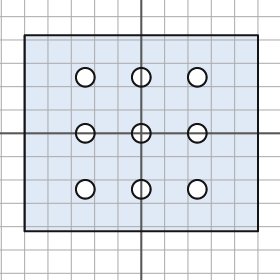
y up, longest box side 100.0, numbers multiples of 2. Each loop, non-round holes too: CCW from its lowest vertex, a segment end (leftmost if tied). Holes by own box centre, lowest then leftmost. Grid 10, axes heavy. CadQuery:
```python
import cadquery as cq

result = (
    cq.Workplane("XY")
    .moveTo(-50.0, -42.0)
    .lineTo(50.0, -42.0)
    .lineTo(50.0, 42.0)
    .lineTo(-50.0, 42.0)
    .close()
    .moveTo(-24.0, -24.0)
    .circle(4.0)
    .moveTo(0.0, -24.0)
    .circle(4.0)
    .moveTo(24.0, -24.0)
    .circle(4.0)
    .moveTo(-24.0, 0.0)
    .circle(4.0)
    .moveTo(0.0, 0.0)
    .circle(4.0)
    .moveTo(24.0, 0.0)
    .circle(4.0)
    .moveTo(-24.0, 24.0)
    .circle(4.0)
    .moveTo(0.0, 24.0)
    .circle(4.0)
    .moveTo(24.0, 24.0)
    .circle(4.0)
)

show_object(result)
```